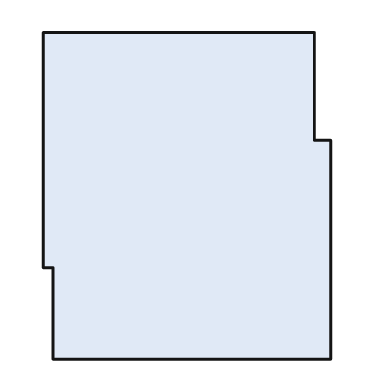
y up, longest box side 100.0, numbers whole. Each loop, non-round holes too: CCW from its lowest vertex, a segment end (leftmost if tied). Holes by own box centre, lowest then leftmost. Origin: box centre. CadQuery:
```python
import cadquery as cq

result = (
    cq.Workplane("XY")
    .moveTo(-41.0, -50.0)
    .lineTo(44.0, -50.0)
    .lineTo(44.0, 17.0)
    .lineTo(39.0, 17.0)
    .lineTo(39.0, 50.0)
    .lineTo(-44.0, 50.0)
    .lineTo(-44.0, -22.0)
    .lineTo(-41.0, -22.0)
    .close()
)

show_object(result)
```